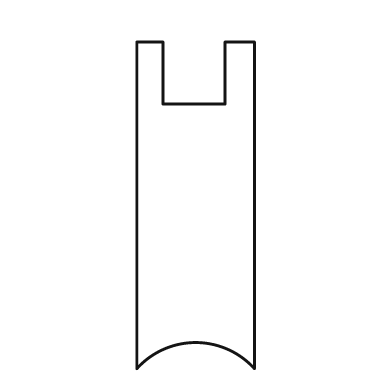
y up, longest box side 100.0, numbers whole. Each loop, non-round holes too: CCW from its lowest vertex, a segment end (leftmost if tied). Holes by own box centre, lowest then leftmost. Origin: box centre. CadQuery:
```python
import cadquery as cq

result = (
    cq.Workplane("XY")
    .moveTo(-18.0, -50.0)
    .threePointArc((0.0, -42.0), (18.0, -50.0))
    .lineTo(18.0, 50.0)
    .lineTo(9.0, 50.0)
    .lineTo(9.0, 31.0)
    .lineTo(-10.0, 31.0)
    .lineTo(-10.0, 50.0)
    .lineTo(-18.0, 50.0)
    .close()
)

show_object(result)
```